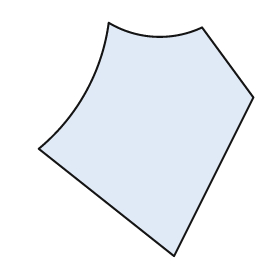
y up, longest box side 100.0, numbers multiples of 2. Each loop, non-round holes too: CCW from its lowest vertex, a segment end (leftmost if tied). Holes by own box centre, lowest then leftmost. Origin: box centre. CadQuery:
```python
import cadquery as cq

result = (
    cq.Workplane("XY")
    .moveTo(12.0, -50.0)
    .lineTo(46.0, 18.0)
    .lineTo(24.0, 48.0)
    .threePointArc((4.0, 44.0), (-16.0, 50.0))
    .threePointArc((-26.0, 20.0), (-46.0, -4.0))
    .close()
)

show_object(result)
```